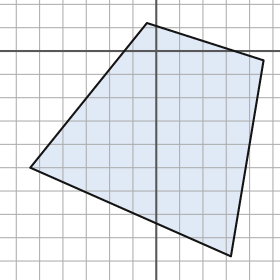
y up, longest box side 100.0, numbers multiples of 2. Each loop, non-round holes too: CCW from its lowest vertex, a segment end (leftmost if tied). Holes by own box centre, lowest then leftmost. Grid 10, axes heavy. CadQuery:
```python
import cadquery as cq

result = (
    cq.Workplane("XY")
    .moveTo(32.0, -88.0)
    .lineTo(46.0, -4.0)
    .lineTo(-4.0, 12.0)
    .lineTo(-54.0, -50.0)
    .close()
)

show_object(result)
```